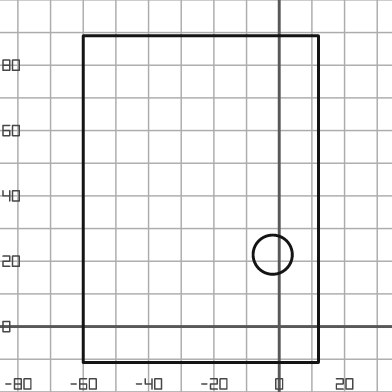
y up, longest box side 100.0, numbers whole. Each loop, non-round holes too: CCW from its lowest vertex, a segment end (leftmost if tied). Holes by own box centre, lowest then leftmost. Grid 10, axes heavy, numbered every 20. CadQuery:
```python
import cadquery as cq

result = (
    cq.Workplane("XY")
    .moveTo(-60.0, -11.0)
    .lineTo(12.0, -11.0)
    .lineTo(12.0, 89.0)
    .lineTo(-60.0, 89.0)
    .close()
    .moveTo(-2.0, 22.0)
    .circle(6.0)
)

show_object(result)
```